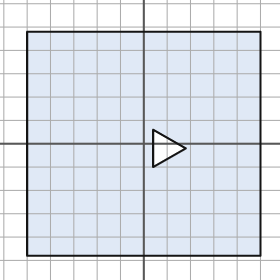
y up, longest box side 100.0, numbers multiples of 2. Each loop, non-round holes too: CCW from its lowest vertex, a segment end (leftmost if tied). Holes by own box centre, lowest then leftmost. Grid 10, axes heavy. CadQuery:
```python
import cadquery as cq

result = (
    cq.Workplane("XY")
    .moveTo(-50.0, -48.0)
    .lineTo(50.0, -48.0)
    .lineTo(50.0, 48.0)
    .lineTo(-50.0, 48.0)
    .close()
    .moveTo(4.0, -10.0)
    .lineTo(18.0, -2.0)
    .lineTo(4.0, 6.0)
    .close()
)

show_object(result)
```